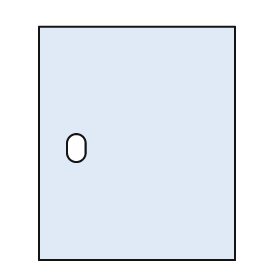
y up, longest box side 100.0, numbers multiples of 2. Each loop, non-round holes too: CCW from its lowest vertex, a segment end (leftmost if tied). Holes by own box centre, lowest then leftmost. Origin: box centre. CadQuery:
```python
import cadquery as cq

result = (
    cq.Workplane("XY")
    .moveTo(-42.0, -50.0)
    .lineTo(42.0, -50.0)
    .lineTo(42.0, 50.0)
    .lineTo(-42.0, 50.0)
    .close()
    .moveTo(-30.0, -4.0)
    .threePointArc((-26.0, -8.0), (-22.0, -4.0))
    .lineTo(-22.0, 0.0)
    .threePointArc((-26.0, 4.0), (-30.0, 0.0))
    .close()
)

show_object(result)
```